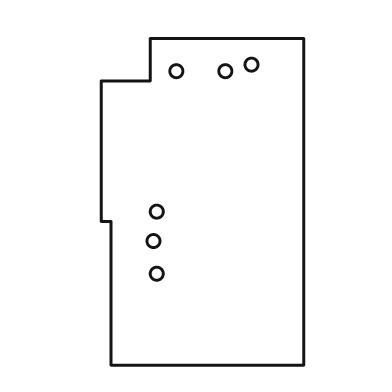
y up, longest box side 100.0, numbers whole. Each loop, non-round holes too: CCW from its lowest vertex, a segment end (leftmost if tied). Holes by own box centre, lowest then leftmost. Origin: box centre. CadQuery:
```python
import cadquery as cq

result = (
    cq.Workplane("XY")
    .moveTo(-28.0, -50.0)
    .lineTo(31.0, -50.0)
    .lineTo(31.0, 50.0)
    .lineTo(-16.0, 50.0)
    .lineTo(-16.0, 37.0)
    .lineTo(-31.0, 37.0)
    .lineTo(-31.0, -6.0)
    .lineTo(-28.0, -6.0)
    .close()
    .moveTo(-14.0, -22.0)
    .circle(2.0)
    .moveTo(-15.0, -12.0)
    .circle(2.0)
    .moveTo(-14.0, -3.0)
    .circle(2.0)
    .moveTo(-8.0, 40.0)
    .circle(2.0)
    .moveTo(7.0, 40.0)
    .circle(2.0)
    .moveTo(15.0, 42.0)
    .circle(2.0)
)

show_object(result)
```